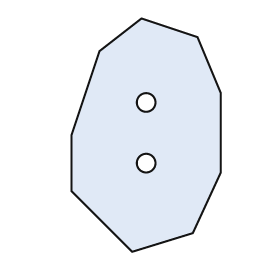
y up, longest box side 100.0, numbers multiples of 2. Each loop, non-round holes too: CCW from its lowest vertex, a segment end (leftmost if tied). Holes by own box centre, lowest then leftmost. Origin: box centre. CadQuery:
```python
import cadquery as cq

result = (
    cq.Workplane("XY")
    .moveTo(-6.0, -50.0)
    .lineTo(20.0, -42.0)
    .lineTo(32.0, -16.0)
    .lineTo(32.0, 18.0)
    .lineTo(22.0, 42.0)
    .lineTo(-2.0, 50.0)
    .lineTo(-20.0, 36.0)
    .lineTo(-32.0, 0.0)
    .lineTo(-32.0, -24.0)
    .close()
    .moveTo(0.0, -12.0)
    .circle(4.0)
    .moveTo(0.0, 14.0)
    .circle(4.0)
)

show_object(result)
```